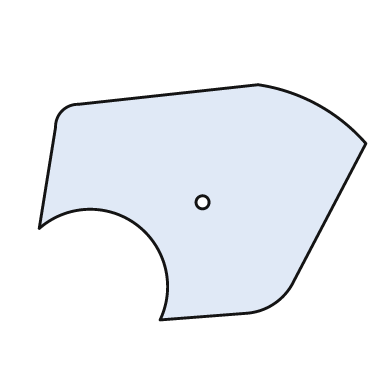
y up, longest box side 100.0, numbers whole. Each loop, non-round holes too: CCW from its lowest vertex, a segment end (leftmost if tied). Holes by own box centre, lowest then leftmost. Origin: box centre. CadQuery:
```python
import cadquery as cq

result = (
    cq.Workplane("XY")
    .moveTo(-13.0, -36.0)
    .lineTo(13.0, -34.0)
    .threePointArc((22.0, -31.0), (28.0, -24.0))
    .lineTo(50.0, 18.0)
    .threePointArc((35.0, 30.0), (17.0, 36.0))
    .lineTo(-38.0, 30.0)
    .threePointArc((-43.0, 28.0), (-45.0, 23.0))
    .lineTo(-50.0, -8.0)
    .threePointArc((-20.0, -7.0), (-13.0, -36.0))
    .close()
    .moveTo(0.0, 0.0)
    .circle(2.0)
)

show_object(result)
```